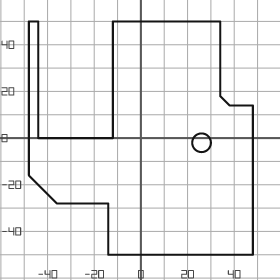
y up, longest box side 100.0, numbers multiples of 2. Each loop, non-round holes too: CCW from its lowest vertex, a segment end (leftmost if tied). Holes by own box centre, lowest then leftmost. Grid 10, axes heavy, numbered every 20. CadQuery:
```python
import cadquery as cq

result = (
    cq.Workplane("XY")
    .moveTo(-14.0, -50.0)
    .lineTo(48.0, -50.0)
    .lineTo(48.0, 14.0)
    .lineTo(38.0, 14.0)
    .lineTo(34.0, 18.0)
    .lineTo(34.0, 50.0)
    .lineTo(-12.0, 50.0)
    .lineTo(-12.0, 0.0)
    .lineTo(-44.0, 0.0)
    .lineTo(-44.0, 50.0)
    .lineTo(-48.0, 50.0)
    .lineTo(-48.0, -16.0)
    .lineTo(-36.0, -28.0)
    .lineTo(-14.0, -28.0)
    .close()
    .moveTo(26.0, -2.0)
    .circle(4.0)
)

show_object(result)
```